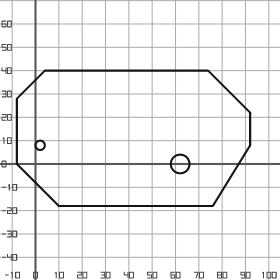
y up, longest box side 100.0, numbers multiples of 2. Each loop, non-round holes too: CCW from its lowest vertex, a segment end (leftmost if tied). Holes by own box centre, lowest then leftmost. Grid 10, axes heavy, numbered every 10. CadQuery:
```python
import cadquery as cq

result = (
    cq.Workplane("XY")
    .moveTo(10.0, -18.0)
    .lineTo(76.0, -18.0)
    .lineTo(92.0, 8.0)
    .lineTo(92.0, 22.0)
    .lineTo(74.0, 40.0)
    .lineTo(4.0, 40.0)
    .lineTo(-8.0, 28.0)
    .lineTo(-8.0, 0.0)
    .close()
    .moveTo(62.0, 0.0)
    .circle(4.0)
    .moveTo(2.0, 8.0)
    .circle(2.0)
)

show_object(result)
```